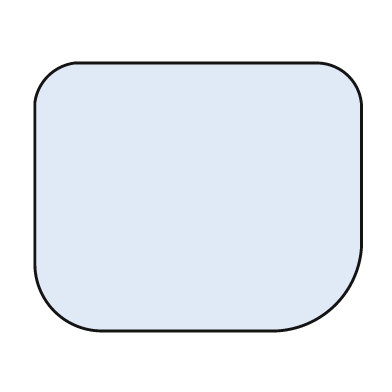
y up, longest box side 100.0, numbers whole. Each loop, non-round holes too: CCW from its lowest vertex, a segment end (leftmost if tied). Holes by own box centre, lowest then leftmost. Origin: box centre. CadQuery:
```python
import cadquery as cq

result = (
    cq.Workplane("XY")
    .moveTo(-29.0, -41.0)
    .lineTo(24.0, -41.0)
    .threePointArc((42.0, -33.0), (50.0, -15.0))
    .lineTo(50.0, 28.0)
    .threePointArc((46.0, 37.0), (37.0, 41.0))
    .lineTo(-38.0, 41.0)
    .threePointArc((-46.0, 37.0), (-50.0, 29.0))
    .lineTo(-50.0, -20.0)
    .threePointArc((-44.0, -35.0), (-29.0, -41.0))
    .close()
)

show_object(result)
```